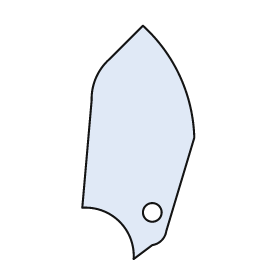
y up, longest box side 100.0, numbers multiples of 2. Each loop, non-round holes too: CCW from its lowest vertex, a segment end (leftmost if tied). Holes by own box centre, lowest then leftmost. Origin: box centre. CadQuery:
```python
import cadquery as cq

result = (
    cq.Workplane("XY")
    .moveTo(-2.0, -50.0)
    .lineTo(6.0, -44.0)
    .threePointArc((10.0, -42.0), (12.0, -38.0))
    .lineTo(24.0, 2.0)
    .threePointArc((18.0, 28.0), (2.0, 50.0))
    .lineTo(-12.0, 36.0)
    .threePointArc((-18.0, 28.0), (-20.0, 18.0))
    .lineTo(-24.0, -28.0)
    .threePointArc((-8.0, -34.0), (-2.0, -50.0))
    .close()
    .moveTo(6.0, -30.0)
    .circle(4.0)
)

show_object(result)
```